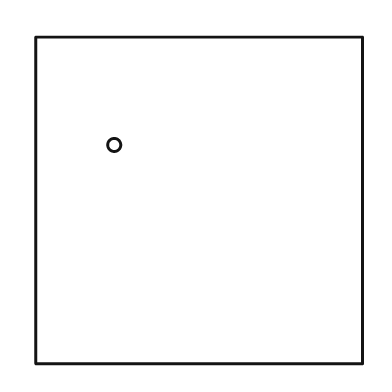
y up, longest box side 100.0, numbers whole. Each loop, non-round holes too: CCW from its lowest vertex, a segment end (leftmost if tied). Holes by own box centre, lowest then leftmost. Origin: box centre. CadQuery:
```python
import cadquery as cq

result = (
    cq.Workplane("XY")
    .moveTo(-50.0, -50.0)
    .lineTo(50.0, -50.0)
    .lineTo(50.0, 50.0)
    .lineTo(-50.0, 50.0)
    .close()
    .moveTo(-26.0, 17.0)
    .circle(2.0)
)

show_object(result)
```